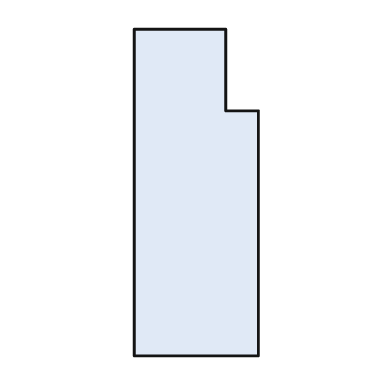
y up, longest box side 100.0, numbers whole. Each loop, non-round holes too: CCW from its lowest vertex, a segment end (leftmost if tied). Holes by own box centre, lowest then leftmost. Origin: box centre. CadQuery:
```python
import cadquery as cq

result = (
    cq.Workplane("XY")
    .moveTo(-19.0, -50.0)
    .lineTo(19.0, -50.0)
    .lineTo(19.0, 25.0)
    .lineTo(9.0, 25.0)
    .lineTo(9.0, 50.0)
    .lineTo(-19.0, 50.0)
    .close()
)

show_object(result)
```